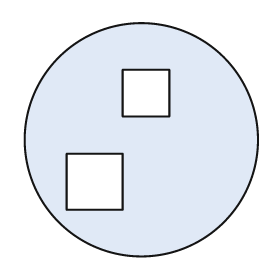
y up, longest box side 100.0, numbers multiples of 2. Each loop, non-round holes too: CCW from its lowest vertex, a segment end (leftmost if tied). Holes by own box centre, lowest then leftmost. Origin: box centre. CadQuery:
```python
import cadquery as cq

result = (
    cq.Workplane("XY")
    .moveTo(0.0, 0.0)
    .circle(50.0)
    .moveTo(-32.0, -30.0)
    .lineTo(-8.0, -30.0)
    .lineTo(-8.0, -6.0)
    .lineTo(-32.0, -6.0)
    .close()
    .moveTo(-8.0, 10.0)
    .lineTo(12.0, 10.0)
    .lineTo(12.0, 30.0)
    .lineTo(-8.0, 30.0)
    .close()
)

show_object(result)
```